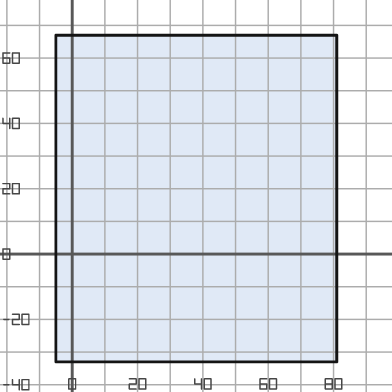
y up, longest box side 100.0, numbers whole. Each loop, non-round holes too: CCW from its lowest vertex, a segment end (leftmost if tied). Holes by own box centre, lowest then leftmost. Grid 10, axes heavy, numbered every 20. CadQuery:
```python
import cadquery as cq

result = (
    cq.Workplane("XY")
    .moveTo(-5.0, -33.0)
    .lineTo(81.0, -33.0)
    .lineTo(81.0, 67.0)
    .lineTo(-5.0, 67.0)
    .close()
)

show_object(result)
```